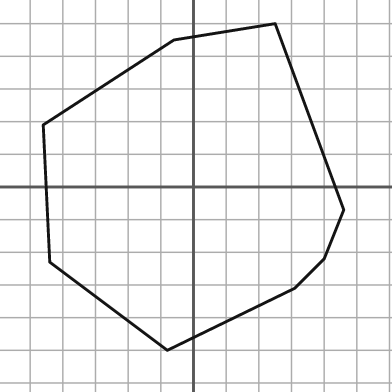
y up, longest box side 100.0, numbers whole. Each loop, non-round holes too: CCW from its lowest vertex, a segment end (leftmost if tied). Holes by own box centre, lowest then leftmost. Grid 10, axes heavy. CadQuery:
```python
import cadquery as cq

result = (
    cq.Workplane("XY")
    .moveTo(-8.0, -50.0)
    .lineTo(31.0, -31.0)
    .lineTo(40.0, -22.0)
    .lineTo(46.0, -7.0)
    .lineTo(25.0, 50.0)
    .lineTo(-6.0, 45.0)
    .lineTo(-46.0, 19.0)
    .lineTo(-44.0, -23.0)
    .close()
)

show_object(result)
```